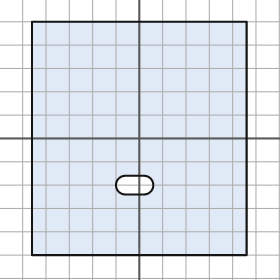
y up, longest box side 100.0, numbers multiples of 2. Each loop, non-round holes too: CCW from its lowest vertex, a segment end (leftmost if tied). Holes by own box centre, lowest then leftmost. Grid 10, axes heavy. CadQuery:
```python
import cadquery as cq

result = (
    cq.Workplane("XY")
    .moveTo(-46.0, -50.0)
    .lineTo(46.0, -50.0)
    .lineTo(46.0, 50.0)
    .lineTo(-46.0, 50.0)
    .close()
    .moveTo(-6.0, -24.0)
    .lineTo(2.0, -24.0)
    .threePointArc((6.0, -20.0), (2.0, -16.0))
    .lineTo(-6.0, -16.0)
    .threePointArc((-10.0, -20.0), (-6.0, -24.0))
    .close()
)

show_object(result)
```